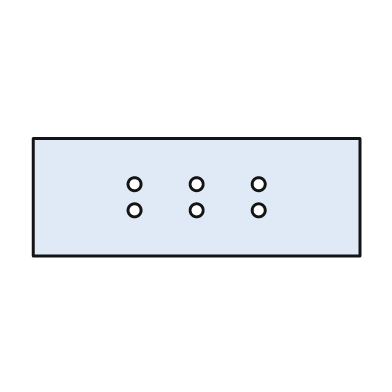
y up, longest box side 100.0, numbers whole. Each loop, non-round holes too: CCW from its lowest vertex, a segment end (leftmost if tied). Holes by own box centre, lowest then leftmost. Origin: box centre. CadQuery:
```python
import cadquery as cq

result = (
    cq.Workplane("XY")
    .moveTo(-50.0, -18.0)
    .lineTo(50.0, -18.0)
    .lineTo(50.0, 18.0)
    .lineTo(-50.0, 18.0)
    .close()
    .moveTo(-19.0, -4.0)
    .circle(2.0)
    .moveTo(0.0, -4.0)
    .circle(2.0)
    .moveTo(19.0, -4.0)
    .circle(2.0)
    .moveTo(-19.0, 4.0)
    .circle(2.0)
    .moveTo(0.0, 4.0)
    .circle(2.0)
    .moveTo(19.0, 4.0)
    .circle(2.0)
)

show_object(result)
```